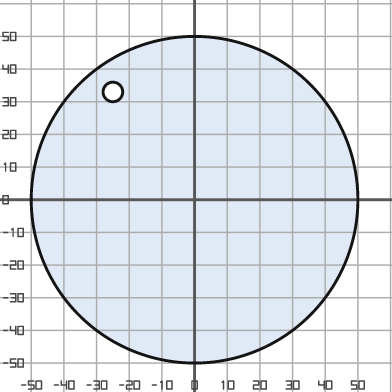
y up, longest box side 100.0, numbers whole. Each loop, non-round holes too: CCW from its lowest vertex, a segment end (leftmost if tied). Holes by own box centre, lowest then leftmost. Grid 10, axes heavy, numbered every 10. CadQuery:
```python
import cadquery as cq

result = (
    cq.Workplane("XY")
    .moveTo(0.0, 0.0)
    .circle(50.0)
    .moveTo(-25.0, 33.0)
    .circle(3.0)
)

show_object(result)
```